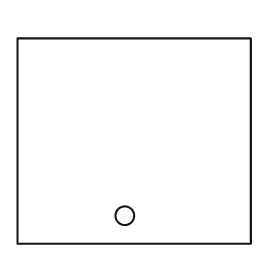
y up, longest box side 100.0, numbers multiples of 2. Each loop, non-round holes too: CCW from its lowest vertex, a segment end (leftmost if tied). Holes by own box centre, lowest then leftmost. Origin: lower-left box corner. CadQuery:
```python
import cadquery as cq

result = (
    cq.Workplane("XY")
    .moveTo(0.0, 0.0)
    .lineTo(100.0, 0.0)
    .lineTo(100.0, 88.0)
    .lineTo(0.0, 88.0)
    .close()
    .moveTo(46.0, 12.0)
    .circle(4.0)
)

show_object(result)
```